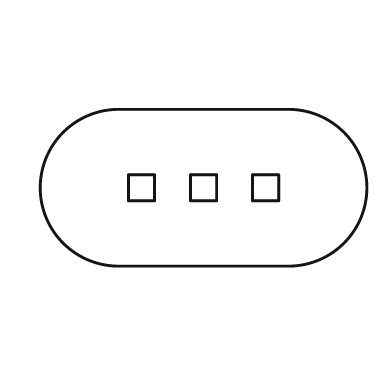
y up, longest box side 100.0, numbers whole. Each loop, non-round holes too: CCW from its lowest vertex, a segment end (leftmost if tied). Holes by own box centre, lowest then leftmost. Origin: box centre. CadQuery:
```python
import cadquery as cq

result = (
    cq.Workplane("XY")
    .moveTo(-26.0, -24.0)
    .lineTo(26.0, -24.0)
    .threePointArc((50.0, 0.0), (26.0, 24.0))
    .lineTo(-26.0, 24.0)
    .threePointArc((-50.0, 0.0), (-26.0, -24.0))
    .close()
    .moveTo(-23.0, -4.0)
    .lineTo(-15.0, -4.0)
    .lineTo(-15.0, 4.0)
    .lineTo(-23.0, 4.0)
    .close()
    .moveTo(-4.0, -4.0)
    .lineTo(4.0, -4.0)
    .lineTo(4.0, 4.0)
    .lineTo(-4.0, 4.0)
    .close()
    .moveTo(15.0, -4.0)
    .lineTo(23.0, -4.0)
    .lineTo(23.0, 4.0)
    .lineTo(15.0, 4.0)
    .close()
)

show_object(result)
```